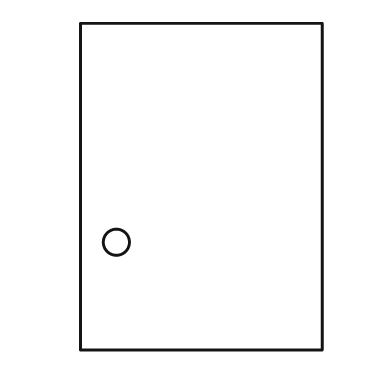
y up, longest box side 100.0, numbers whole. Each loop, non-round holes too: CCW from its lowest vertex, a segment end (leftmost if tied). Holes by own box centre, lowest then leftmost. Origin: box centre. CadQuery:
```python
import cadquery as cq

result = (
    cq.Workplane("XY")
    .moveTo(-37.0, -50.0)
    .lineTo(37.0, -50.0)
    .lineTo(37.0, 50.0)
    .lineTo(-37.0, 50.0)
    .close()
    .moveTo(-26.0, -17.0)
    .circle(4.0)
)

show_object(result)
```